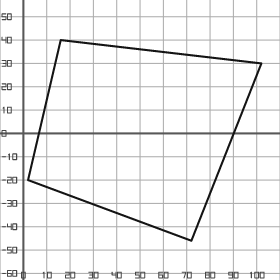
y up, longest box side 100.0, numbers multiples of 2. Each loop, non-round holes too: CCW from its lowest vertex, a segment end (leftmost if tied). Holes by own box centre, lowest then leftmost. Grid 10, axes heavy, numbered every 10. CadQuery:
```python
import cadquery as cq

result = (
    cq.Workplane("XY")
    .moveTo(72.0, -46.0)
    .lineTo(102.0, 30.0)
    .lineTo(16.0, 40.0)
    .lineTo(2.0, -20.0)
    .close()
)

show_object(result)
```